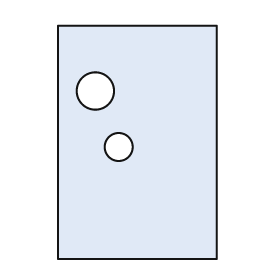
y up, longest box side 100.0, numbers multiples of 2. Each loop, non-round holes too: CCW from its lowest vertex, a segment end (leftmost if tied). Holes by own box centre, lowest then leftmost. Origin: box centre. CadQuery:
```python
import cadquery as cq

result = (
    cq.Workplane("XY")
    .moveTo(-34.0, -50.0)
    .lineTo(34.0, -50.0)
    .lineTo(34.0, 50.0)
    .lineTo(-34.0, 50.0)
    .close()
    .moveTo(-8.0, -2.0)
    .circle(6.0)
    .moveTo(-18.0, 22.0)
    .circle(8.0)
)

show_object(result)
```